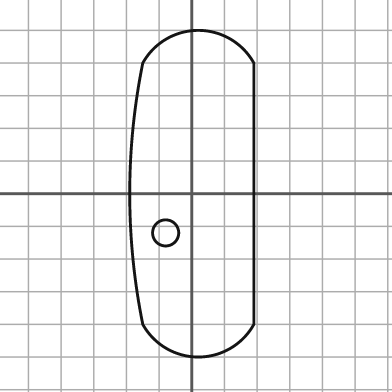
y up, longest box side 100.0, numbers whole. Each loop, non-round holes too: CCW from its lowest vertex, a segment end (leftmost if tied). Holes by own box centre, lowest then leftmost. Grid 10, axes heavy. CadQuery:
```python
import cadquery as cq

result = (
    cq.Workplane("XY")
    .moveTo(-15.0, -40.0)
    .threePointArc((2.0, -50.0), (19.0, -40.0))
    .lineTo(19.0, 40.0)
    .threePointArc((2.0, 50.0), (-15.0, 40.0))
    .threePointArc((-19.0, 0.0), (-15.0, -40.0))
    .close()
    .moveTo(-8.0, -12.0)
    .circle(4.0)
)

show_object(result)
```